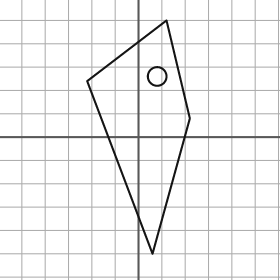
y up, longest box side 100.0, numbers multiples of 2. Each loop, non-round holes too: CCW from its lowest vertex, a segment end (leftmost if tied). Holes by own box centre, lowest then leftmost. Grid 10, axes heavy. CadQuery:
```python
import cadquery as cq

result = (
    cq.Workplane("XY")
    .moveTo(6.0, -50.0)
    .lineTo(22.0, 8.0)
    .lineTo(12.0, 50.0)
    .lineTo(-22.0, 24.0)
    .close()
    .moveTo(8.0, 26.0)
    .circle(4.0)
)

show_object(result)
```